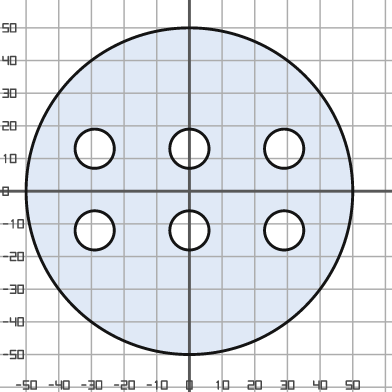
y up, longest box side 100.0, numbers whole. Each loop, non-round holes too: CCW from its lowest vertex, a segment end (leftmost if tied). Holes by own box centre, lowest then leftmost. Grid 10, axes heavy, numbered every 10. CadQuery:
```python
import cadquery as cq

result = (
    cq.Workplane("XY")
    .moveTo(0.0, 0.0)
    .circle(50.0)
    .moveTo(-29.0, -12.0)
    .circle(6.0)
    .moveTo(0.0, -12.0)
    .circle(6.0)
    .moveTo(29.0, -12.0)
    .circle(6.0)
    .moveTo(-29.0, 13.0)
    .circle(6.0)
    .moveTo(0.0, 13.0)
    .circle(6.0)
    .moveTo(29.0, 13.0)
    .circle(6.0)
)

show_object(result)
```